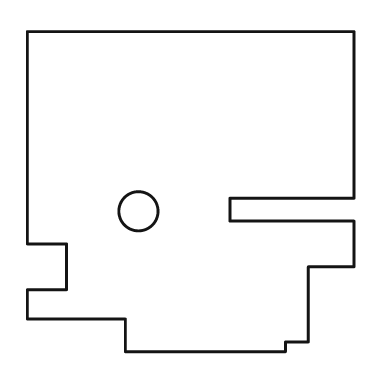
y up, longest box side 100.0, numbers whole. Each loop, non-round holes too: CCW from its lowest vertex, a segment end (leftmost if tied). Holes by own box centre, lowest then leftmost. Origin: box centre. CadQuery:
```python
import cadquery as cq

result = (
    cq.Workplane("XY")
    .moveTo(-20.0, -49.0)
    .lineTo(29.0, -49.0)
    .lineTo(29.0, -46.0)
    .lineTo(36.0, -46.0)
    .lineTo(36.0, -23.0)
    .lineTo(50.0, -23.0)
    .lineTo(50.0, -9.0)
    .lineTo(12.0, -9.0)
    .lineTo(12.0, -2.0)
    .lineTo(50.0, -2.0)
    .lineTo(50.0, 49.0)
    .lineTo(-50.0, 49.0)
    .lineTo(-50.0, -16.0)
    .lineTo(-38.0, -16.0)
    .lineTo(-38.0, -30.0)
    .lineTo(-50.0, -30.0)
    .lineTo(-50.0, -39.0)
    .lineTo(-20.0, -39.0)
    .close()
    .moveTo(-16.0, -6.0)
    .circle(6.0)
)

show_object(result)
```